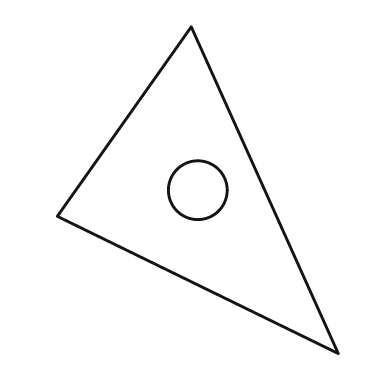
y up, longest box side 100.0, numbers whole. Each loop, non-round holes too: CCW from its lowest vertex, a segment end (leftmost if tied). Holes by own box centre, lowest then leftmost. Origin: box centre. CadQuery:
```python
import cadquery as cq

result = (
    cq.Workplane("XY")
    .moveTo(43.0, -50.0)
    .lineTo(-2.0, 50.0)
    .lineTo(-43.0, -8.0)
    .close()
    .moveTo(0.0, 0.0)
    .circle(9.0)
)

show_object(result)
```